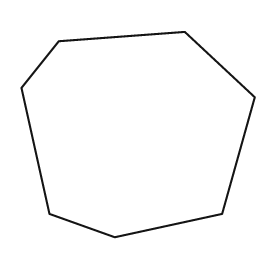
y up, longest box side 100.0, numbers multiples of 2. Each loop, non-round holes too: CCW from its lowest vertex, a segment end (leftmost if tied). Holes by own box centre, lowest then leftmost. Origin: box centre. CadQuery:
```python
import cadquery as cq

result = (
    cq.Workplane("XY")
    .moveTo(-10.0, -44.0)
    .lineTo(36.0, -34.0)
    .lineTo(50.0, 16.0)
    .lineTo(20.0, 44.0)
    .lineTo(-34.0, 40.0)
    .lineTo(-50.0, 20.0)
    .lineTo(-38.0, -34.0)
    .close()
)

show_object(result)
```